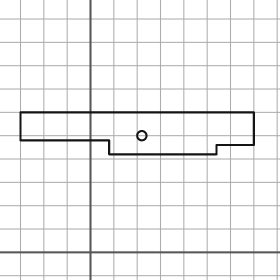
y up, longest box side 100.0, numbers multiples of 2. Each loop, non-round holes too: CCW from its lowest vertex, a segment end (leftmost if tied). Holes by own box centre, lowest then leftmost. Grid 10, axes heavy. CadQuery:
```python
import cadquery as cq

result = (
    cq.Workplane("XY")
    .moveTo(8.0, 42.0)
    .lineTo(54.0, 42.0)
    .lineTo(54.0, 46.0)
    .lineTo(70.0, 46.0)
    .lineTo(70.0, 60.0)
    .lineTo(-30.0, 60.0)
    .lineTo(-30.0, 48.0)
    .lineTo(8.0, 48.0)
    .close()
    .moveTo(22.0, 50.0)
    .circle(2.0)
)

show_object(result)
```